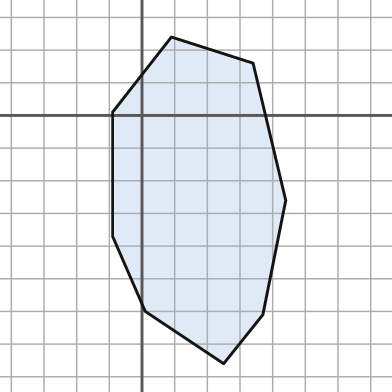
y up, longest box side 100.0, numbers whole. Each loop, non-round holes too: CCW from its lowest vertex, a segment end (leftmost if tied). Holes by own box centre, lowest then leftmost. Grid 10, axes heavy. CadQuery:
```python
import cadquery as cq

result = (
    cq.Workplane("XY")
    .moveTo(25.0, -76.0)
    .lineTo(37.0, -61.0)
    .lineTo(44.0, -26.0)
    .lineTo(34.0, 16.0)
    .lineTo(9.0, 24.0)
    .lineTo(-9.0, 1.0)
    .lineTo(-9.0, -37.0)
    .lineTo(1.0, -60.0)
    .close()
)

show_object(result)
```